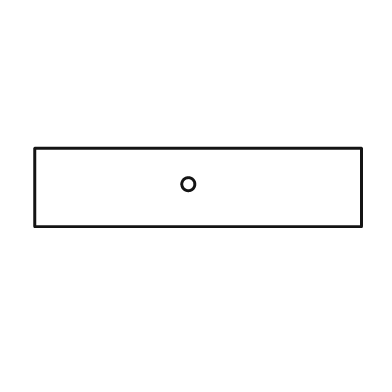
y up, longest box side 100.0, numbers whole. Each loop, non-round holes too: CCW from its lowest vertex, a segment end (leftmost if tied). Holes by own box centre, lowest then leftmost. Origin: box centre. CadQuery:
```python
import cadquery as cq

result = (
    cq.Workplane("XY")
    .moveTo(-50.0, -12.0)
    .lineTo(50.0, -12.0)
    .lineTo(50.0, 12.0)
    .lineTo(-50.0, 12.0)
    .close()
    .moveTo(-3.0, 1.0)
    .circle(2.0)
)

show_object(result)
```